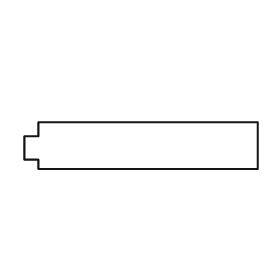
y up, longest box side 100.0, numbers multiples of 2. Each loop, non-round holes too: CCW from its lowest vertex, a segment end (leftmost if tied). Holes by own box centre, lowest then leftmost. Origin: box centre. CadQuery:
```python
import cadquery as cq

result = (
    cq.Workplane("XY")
    .moveTo(-44.0, -10.0)
    .lineTo(50.0, -10.0)
    .lineTo(50.0, 10.0)
    .lineTo(-44.0, 10.0)
    .lineTo(-44.0, 4.0)
    .lineTo(-50.0, 4.0)
    .lineTo(-50.0, -6.0)
    .lineTo(-44.0, -6.0)
    .close()
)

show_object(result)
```